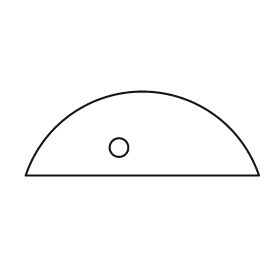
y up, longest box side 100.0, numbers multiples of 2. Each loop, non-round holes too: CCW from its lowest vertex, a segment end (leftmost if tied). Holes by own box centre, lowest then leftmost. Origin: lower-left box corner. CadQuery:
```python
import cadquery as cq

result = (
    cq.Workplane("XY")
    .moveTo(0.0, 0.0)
    .lineTo(100.0, 0.0)
    .threePointArc((50.0, 36.0), (0.0, 0.0))
    .close()
    .moveTo(40.0, 12.0)
    .circle(4.0)
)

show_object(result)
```